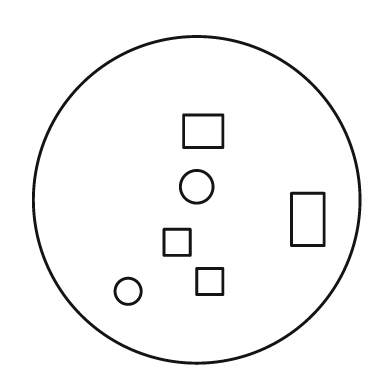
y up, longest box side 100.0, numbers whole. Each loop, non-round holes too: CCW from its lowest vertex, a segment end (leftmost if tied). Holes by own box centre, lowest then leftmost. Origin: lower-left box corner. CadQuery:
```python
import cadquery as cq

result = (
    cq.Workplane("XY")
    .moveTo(50.0, 50.0)
    .circle(50.0)
    .moveTo(29.0, 22.0)
    .circle(4.0)
    .moveTo(50.0, 21.0)
    .lineTo(58.0, 21.0)
    .lineTo(58.0, 29.0)
    .lineTo(50.0, 29.0)
    .close()
    .moveTo(40.0, 33.0)
    .lineTo(48.0, 33.0)
    .lineTo(48.0, 41.0)
    .lineTo(40.0, 41.0)
    .close()
    .moveTo(79.0, 36.0)
    .lineTo(89.0, 36.0)
    .lineTo(89.0, 52.0)
    .lineTo(79.0, 52.0)
    .close()
    .moveTo(50.0, 54.0)
    .circle(5.0)
    .moveTo(46.0, 66.0)
    .lineTo(58.0, 66.0)
    .lineTo(58.0, 76.0)
    .lineTo(46.0, 76.0)
    .close()
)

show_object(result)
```